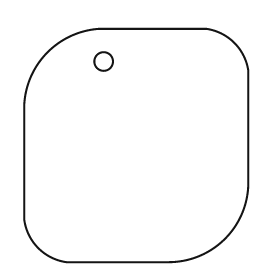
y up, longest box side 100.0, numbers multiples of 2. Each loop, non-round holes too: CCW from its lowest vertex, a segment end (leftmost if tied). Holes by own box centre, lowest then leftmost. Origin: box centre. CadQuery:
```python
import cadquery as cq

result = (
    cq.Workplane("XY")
    .moveTo(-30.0, -50.0)
    .lineTo(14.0, -50.0)
    .threePointArc((38.0, -40.0), (48.0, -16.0))
    .lineTo(48.0, 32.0)
    .threePointArc((42.0, 44.0), (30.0, 50.0))
    .lineTo(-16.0, 50.0)
    .threePointArc((-38.0, 40.0), (-48.0, 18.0))
    .lineTo(-48.0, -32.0)
    .threePointArc((-42.0, -44.0), (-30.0, -50.0))
    .close()
    .moveTo(-14.0, 36.0)
    .circle(4.0)
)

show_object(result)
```